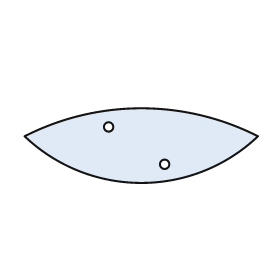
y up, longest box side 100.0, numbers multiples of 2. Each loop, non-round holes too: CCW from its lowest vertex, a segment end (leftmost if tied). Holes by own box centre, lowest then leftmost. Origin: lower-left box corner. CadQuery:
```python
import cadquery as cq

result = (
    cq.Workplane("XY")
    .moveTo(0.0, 20.0)
    .threePointArc((50.0, 0.0), (100.0, 20.0))
    .threePointArc((50.0, 32.0), (0.0, 20.0))
    .close()
    .moveTo(60.0, 8.0)
    .circle(2.0)
    .moveTo(36.0, 24.0)
    .circle(2.0)
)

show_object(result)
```